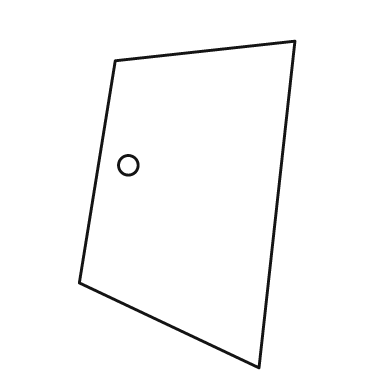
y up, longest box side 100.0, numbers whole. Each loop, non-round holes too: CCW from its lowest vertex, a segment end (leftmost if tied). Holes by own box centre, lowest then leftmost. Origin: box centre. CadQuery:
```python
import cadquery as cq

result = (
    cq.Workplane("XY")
    .moveTo(22.0, -50.0)
    .lineTo(33.0, 50.0)
    .lineTo(-22.0, 44.0)
    .lineTo(-33.0, -24.0)
    .close()
    .moveTo(-18.0, 12.0)
    .circle(3.0)
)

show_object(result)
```